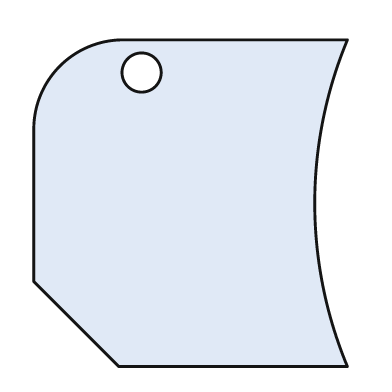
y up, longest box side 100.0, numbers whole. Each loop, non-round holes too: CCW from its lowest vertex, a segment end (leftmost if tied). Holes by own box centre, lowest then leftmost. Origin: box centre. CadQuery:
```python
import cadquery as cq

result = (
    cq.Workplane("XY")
    .moveTo(-22.0, -50.0)
    .lineTo(48.0, -50.0)
    .threePointArc((38.0, 0.0), (48.0, 50.0))
    .lineTo(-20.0, 50.0)
    .threePointArc((-40.0, 42.0), (-48.0, 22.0))
    .lineTo(-48.0, -24.0)
    .close()
    .moveTo(-15.0, 40.0)
    .circle(6.0)
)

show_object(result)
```